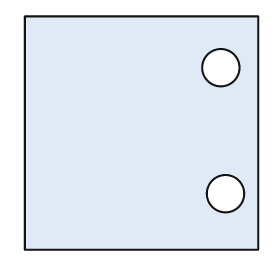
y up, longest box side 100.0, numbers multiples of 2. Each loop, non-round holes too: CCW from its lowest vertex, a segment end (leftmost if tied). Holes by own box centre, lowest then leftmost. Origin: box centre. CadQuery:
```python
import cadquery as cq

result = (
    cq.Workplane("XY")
    .moveTo(-50.0, -50.0)
    .lineTo(50.0, -50.0)
    .lineTo(50.0, 50.0)
    .lineTo(-50.0, 50.0)
    .close()
    .moveTo(36.0, -26.0)
    .circle(8.0)
    .moveTo(34.0, 28.0)
    .circle(8.0)
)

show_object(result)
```